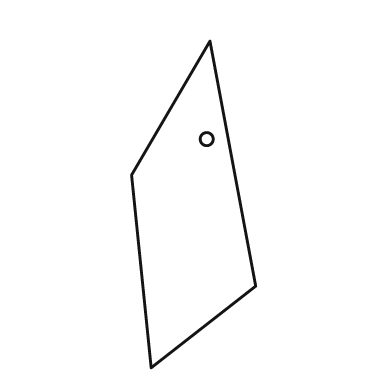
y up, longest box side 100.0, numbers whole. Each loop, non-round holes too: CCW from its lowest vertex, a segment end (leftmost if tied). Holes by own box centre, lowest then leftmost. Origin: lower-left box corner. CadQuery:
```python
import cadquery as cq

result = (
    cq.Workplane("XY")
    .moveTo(6.0, 0.0)
    .lineTo(38.0, 25.0)
    .lineTo(24.0, 100.0)
    .lineTo(0.0, 59.0)
    .close()
    .moveTo(23.0, 70.0)
    .circle(2.0)
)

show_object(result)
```